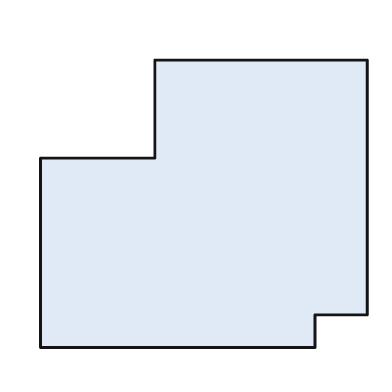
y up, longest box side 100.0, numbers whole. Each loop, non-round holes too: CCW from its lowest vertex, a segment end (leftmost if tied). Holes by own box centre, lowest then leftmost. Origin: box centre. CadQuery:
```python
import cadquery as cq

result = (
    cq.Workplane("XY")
    .moveTo(-50.0, -44.0)
    .lineTo(34.0, -44.0)
    .lineTo(34.0, -34.0)
    .lineTo(50.0, -34.0)
    .lineTo(50.0, 44.0)
    .lineTo(-15.0, 44.0)
    .lineTo(-15.0, 14.0)
    .lineTo(-50.0, 14.0)
    .close()
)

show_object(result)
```